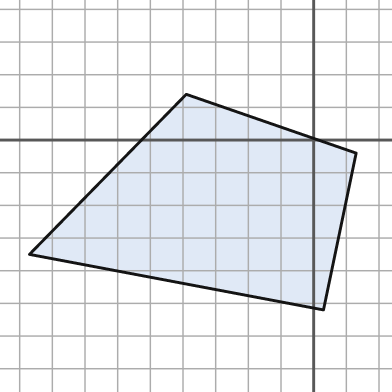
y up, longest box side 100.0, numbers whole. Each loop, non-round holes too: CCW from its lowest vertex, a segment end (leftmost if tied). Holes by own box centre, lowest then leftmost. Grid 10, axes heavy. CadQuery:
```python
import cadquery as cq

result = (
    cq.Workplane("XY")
    .moveTo(3.0, -52.0)
    .lineTo(13.0, -4.0)
    .lineTo(-39.0, 14.0)
    .lineTo(-87.0, -35.0)
    .close()
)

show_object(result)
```